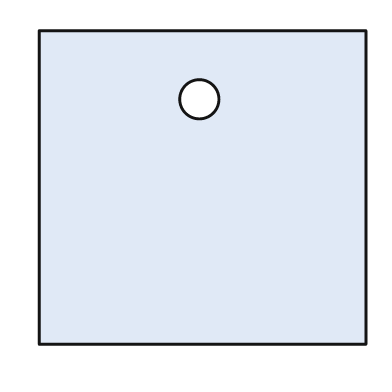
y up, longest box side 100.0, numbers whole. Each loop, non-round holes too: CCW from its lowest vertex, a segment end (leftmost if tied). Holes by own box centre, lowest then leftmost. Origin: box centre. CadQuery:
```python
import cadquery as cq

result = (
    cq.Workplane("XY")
    .moveTo(-50.0, -48.0)
    .lineTo(50.0, -48.0)
    .lineTo(50.0, 48.0)
    .lineTo(-50.0, 48.0)
    .close()
    .moveTo(-1.0, 27.0)
    .circle(6.0)
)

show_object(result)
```